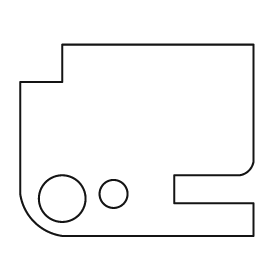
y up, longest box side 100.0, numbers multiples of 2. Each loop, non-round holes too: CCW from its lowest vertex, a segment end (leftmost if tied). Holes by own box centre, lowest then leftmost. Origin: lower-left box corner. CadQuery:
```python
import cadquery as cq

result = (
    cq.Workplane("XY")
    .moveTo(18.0, 0.0)
    .lineTo(100.0, 0.0)
    .lineTo(100.0, 14.0)
    .lineTo(66.0, 14.0)
    .lineTo(66.0, 26.0)
    .lineTo(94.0, 26.0)
    .threePointArc((98.0, 28.0), (100.0, 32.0))
    .lineTo(100.0, 82.0)
    .lineTo(18.0, 82.0)
    .lineTo(18.0, 66.0)
    .lineTo(0.0, 66.0)
    .lineTo(0.0, 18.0)
    .threePointArc((6.0, 6.0), (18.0, 0.0))
    .close()
    .moveTo(18.0, 16.0)
    .circle(10.0)
    .moveTo(40.0, 18.0)
    .circle(6.0)
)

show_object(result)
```